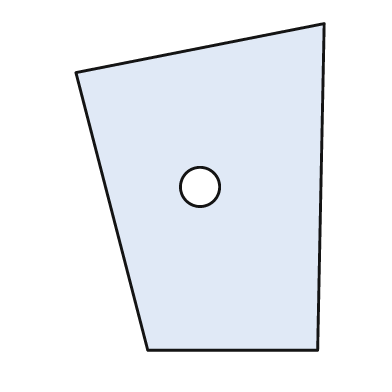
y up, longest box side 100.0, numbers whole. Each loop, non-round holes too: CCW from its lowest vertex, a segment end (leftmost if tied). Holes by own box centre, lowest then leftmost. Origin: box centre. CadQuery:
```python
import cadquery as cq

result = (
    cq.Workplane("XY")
    .moveTo(-16.0, -50.0)
    .lineTo(36.0, -50.0)
    .lineTo(38.0, 50.0)
    .lineTo(-38.0, 35.0)
    .close()
    .moveTo(0.0, 0.0)
    .circle(6.0)
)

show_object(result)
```